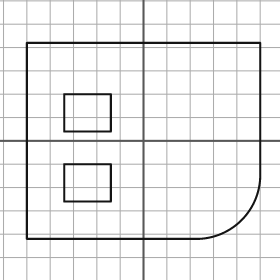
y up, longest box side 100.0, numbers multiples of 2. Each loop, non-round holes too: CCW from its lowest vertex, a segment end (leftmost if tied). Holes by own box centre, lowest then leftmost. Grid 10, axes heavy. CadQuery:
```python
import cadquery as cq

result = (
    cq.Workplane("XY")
    .moveTo(-50.0, -42.0)
    .lineTo(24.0, -42.0)
    .threePointArc((42.0, -34.0), (50.0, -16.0))
    .lineTo(50.0, 42.0)
    .lineTo(-50.0, 42.0)
    .close()
    .moveTo(-34.0, -26.0)
    .lineTo(-14.0, -26.0)
    .lineTo(-14.0, -10.0)
    .lineTo(-34.0, -10.0)
    .close()
    .moveTo(-34.0, 4.0)
    .lineTo(-14.0, 4.0)
    .lineTo(-14.0, 20.0)
    .lineTo(-34.0, 20.0)
    .close()
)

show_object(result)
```